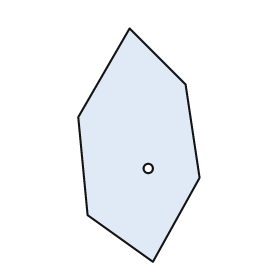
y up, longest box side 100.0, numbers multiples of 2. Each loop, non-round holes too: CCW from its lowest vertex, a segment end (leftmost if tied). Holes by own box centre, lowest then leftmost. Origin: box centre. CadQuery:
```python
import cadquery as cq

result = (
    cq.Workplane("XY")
    .moveTo(6.0, -50.0)
    .lineTo(26.0, -14.0)
    .lineTo(20.0, 26.0)
    .lineTo(-4.0, 50.0)
    .lineTo(-26.0, 12.0)
    .lineTo(-22.0, -30.0)
    .close()
    .moveTo(4.0, -10.0)
    .circle(2.0)
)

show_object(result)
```